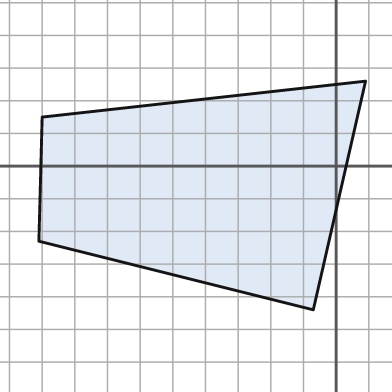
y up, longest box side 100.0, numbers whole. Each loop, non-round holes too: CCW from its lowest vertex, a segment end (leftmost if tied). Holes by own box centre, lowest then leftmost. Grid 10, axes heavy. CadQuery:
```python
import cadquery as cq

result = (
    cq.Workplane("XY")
    .moveTo(-7.0, -44.0)
    .lineTo(9.0, 26.0)
    .lineTo(-90.0, 15.0)
    .lineTo(-91.0, -23.0)
    .close()
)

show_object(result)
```